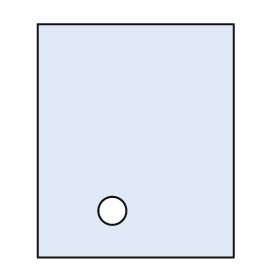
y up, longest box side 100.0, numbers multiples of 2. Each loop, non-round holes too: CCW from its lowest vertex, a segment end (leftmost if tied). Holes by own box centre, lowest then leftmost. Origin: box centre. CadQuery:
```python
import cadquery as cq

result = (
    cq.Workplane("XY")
    .moveTo(-42.0, -50.0)
    .lineTo(42.0, -50.0)
    .lineTo(42.0, 50.0)
    .lineTo(-42.0, 50.0)
    .close()
    .moveTo(-10.0, -30.0)
    .circle(6.0)
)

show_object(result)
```